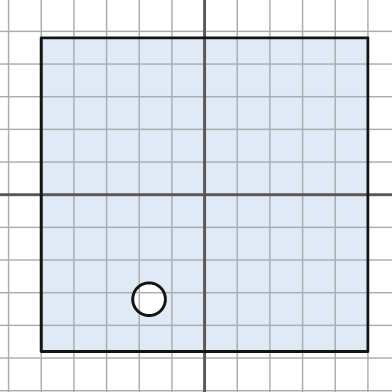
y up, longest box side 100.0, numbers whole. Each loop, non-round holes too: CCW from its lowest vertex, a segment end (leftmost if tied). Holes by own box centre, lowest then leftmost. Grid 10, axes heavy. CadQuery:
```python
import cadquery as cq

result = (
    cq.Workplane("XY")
    .moveTo(-50.0, -48.0)
    .lineTo(50.0, -48.0)
    .lineTo(50.0, 48.0)
    .lineTo(-50.0, 48.0)
    .close()
    .moveTo(-17.0, -32.0)
    .circle(5.0)
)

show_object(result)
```